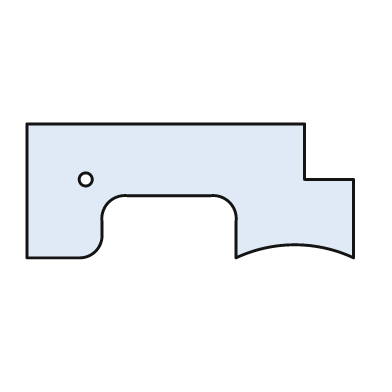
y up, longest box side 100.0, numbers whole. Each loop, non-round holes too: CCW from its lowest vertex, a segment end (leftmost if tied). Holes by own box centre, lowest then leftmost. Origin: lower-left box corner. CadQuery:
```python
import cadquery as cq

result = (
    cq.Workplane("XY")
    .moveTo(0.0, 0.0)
    .lineTo(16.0, 0.0)
    .threePointArc((21.0, 2.0), (23.0, 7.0))
    .lineTo(23.0, 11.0)
    .threePointArc((25.0, 17.0), (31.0, 19.0))
    .lineTo(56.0, 19.0)
    .threePointArc((62.0, 17.0), (64.0, 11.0))
    .lineTo(64.0, 0.0)
    .threePointArc((82.0, 4.0), (100.0, 0.0))
    .lineTo(100.0, 24.0)
    .lineTo(85.0, 24.0)
    .lineTo(85.0, 41.0)
    .lineTo(0.0, 41.0)
    .close()
    .moveTo(18.0, 24.0)
    .circle(2.0)
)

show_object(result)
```